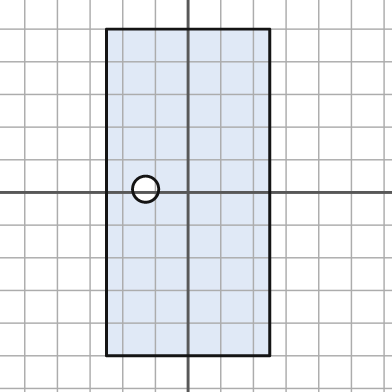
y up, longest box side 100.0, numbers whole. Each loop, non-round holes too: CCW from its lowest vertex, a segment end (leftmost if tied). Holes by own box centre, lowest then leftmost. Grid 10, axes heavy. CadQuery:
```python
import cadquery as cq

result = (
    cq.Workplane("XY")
    .moveTo(-25.0, -50.0)
    .lineTo(25.0, -50.0)
    .lineTo(25.0, 50.0)
    .lineTo(-25.0, 50.0)
    .close()
    .moveTo(-13.0, 1.0)
    .circle(4.0)
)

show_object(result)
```